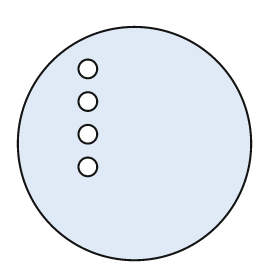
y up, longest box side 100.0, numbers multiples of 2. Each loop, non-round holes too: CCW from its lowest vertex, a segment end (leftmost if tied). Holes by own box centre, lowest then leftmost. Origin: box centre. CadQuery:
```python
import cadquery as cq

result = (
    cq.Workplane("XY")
    .moveTo(0.0, 0.0)
    .circle(50.0)
    .moveTo(-20.0, -10.0)
    .circle(4.0)
    .moveTo(-20.0, 4.0)
    .circle(4.0)
    .moveTo(-20.0, 18.0)
    .circle(4.0)
    .moveTo(-20.0, 32.0)
    .circle(4.0)
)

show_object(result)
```